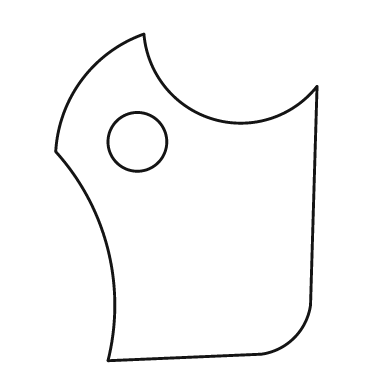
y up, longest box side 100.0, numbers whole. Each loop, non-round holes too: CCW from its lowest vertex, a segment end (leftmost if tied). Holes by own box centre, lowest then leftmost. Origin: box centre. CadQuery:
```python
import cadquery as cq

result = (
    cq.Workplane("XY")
    .moveTo(-24.0, -50.0)
    .lineTo(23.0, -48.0)
    .threePointArc((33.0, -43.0), (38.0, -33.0))
    .lineTo(40.0, 34.0)
    .threePointArc((8.0, 24.0), (-13.0, 50.0))
    .threePointArc((-32.0, 36.0), (-40.0, 14.0))
    .threePointArc((-24.0, -16.0), (-24.0, -50.0))
    .close()
    .moveTo(-15.0, 17.0)
    .circle(9.0)
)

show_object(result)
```